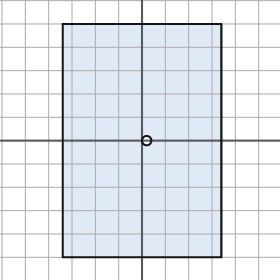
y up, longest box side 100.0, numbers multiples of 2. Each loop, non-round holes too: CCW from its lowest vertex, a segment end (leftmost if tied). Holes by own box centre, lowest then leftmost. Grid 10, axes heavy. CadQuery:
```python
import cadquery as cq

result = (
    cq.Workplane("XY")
    .moveTo(-34.0, -50.0)
    .lineTo(34.0, -50.0)
    .lineTo(34.0, 50.0)
    .lineTo(-34.0, 50.0)
    .close()
    .moveTo(2.0, 0.0)
    .circle(2.0)
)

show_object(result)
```